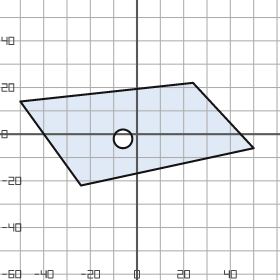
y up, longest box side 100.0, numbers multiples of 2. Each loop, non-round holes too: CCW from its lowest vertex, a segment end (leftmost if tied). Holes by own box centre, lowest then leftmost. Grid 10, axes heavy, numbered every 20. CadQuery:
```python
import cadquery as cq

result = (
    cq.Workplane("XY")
    .moveTo(-24.0, -22.0)
    .lineTo(50.0, -6.0)
    .lineTo(24.0, 22.0)
    .lineTo(-50.0, 14.0)
    .close()
    .moveTo(-6.0, -2.0)
    .circle(4.0)
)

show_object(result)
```